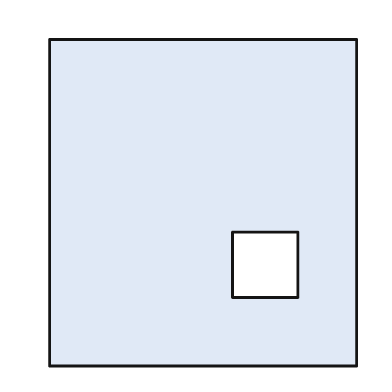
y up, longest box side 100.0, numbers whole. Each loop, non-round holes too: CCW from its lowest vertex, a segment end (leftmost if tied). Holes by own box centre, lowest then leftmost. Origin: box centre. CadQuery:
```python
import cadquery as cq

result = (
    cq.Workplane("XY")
    .moveTo(-47.0, -50.0)
    .lineTo(47.0, -50.0)
    .lineTo(47.0, 50.0)
    .lineTo(-47.0, 50.0)
    .close()
    .moveTo(9.0, -29.0)
    .lineTo(29.0, -29.0)
    .lineTo(29.0, -9.0)
    .lineTo(9.0, -9.0)
    .close()
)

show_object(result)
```